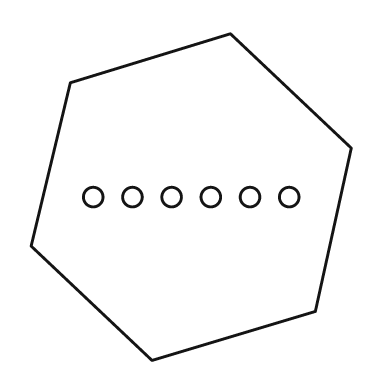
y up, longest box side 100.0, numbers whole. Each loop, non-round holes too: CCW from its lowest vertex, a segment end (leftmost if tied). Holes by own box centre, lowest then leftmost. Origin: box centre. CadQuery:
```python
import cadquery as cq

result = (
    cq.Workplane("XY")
    .moveTo(-12.0, -50.0)
    .lineTo(38.0, -35.0)
    .lineTo(49.0, 15.0)
    .lineTo(12.0, 50.0)
    .lineTo(-37.0, 35.0)
    .lineTo(-49.0, -15.0)
    .close()
    .moveTo(-30.0, 0.0)
    .circle(3.0)
    .moveTo(-18.0, 0.0)
    .circle(3.0)
    .moveTo(-6.0, 0.0)
    .circle(3.0)
    .moveTo(6.0, 0.0)
    .circle(3.0)
    .moveTo(18.0, 0.0)
    .circle(3.0)
    .moveTo(30.0, 0.0)
    .circle(3.0)
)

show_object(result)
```